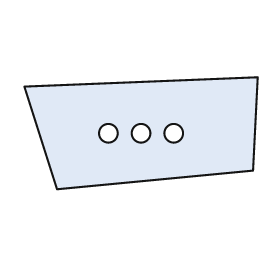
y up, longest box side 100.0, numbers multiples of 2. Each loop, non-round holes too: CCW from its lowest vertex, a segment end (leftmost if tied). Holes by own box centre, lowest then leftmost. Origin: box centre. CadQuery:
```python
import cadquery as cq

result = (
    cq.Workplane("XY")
    .moveTo(-36.0, -24.0)
    .lineTo(48.0, -16.0)
    .lineTo(50.0, 24.0)
    .lineTo(-50.0, 20.0)
    .close()
    .moveTo(-14.0, 0.0)
    .circle(4.0)
    .moveTo(0.0, 0.0)
    .circle(4.0)
    .moveTo(14.0, 0.0)
    .circle(4.0)
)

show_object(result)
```